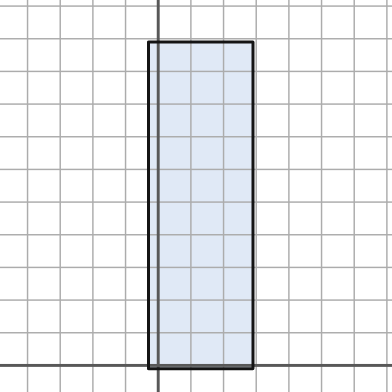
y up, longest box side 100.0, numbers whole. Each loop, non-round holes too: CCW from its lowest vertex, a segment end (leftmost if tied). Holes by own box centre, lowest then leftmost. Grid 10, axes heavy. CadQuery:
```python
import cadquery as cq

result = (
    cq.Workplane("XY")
    .moveTo(-3.0, -1.0)
    .lineTo(29.0, -1.0)
    .lineTo(29.0, 99.0)
    .lineTo(-3.0, 99.0)
    .close()
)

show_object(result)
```